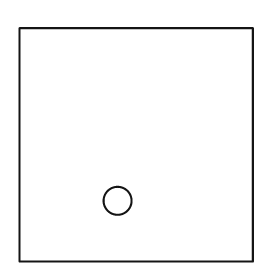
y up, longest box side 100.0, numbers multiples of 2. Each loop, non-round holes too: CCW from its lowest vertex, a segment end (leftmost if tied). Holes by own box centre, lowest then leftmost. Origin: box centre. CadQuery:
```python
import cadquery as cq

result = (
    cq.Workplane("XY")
    .moveTo(-50.0, -50.0)
    .lineTo(50.0, -50.0)
    .lineTo(50.0, 50.0)
    .lineTo(-50.0, 50.0)
    .close()
    .moveTo(-8.0, -24.0)
    .circle(6.0)
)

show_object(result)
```